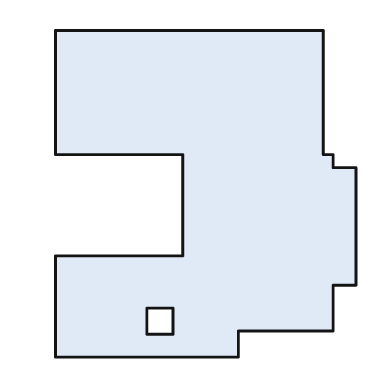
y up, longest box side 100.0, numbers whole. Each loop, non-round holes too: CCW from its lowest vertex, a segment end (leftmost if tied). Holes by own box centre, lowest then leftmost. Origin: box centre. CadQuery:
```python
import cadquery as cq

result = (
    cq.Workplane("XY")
    .moveTo(-46.0, -50.0)
    .lineTo(10.0, -50.0)
    .lineTo(10.0, -42.0)
    .lineTo(39.0, -42.0)
    .lineTo(39.0, -28.0)
    .lineTo(46.0, -28.0)
    .lineTo(46.0, 8.0)
    .lineTo(39.0, 8.0)
    .lineTo(39.0, 12.0)
    .lineTo(36.0, 12.0)
    .lineTo(36.0, 50.0)
    .lineTo(-46.0, 50.0)
    .lineTo(-46.0, 12.0)
    .lineTo(-7.0, 12.0)
    .lineTo(-7.0, -19.0)
    .lineTo(-46.0, -19.0)
    .close()
    .moveTo(-18.0, -43.0)
    .lineTo(-10.0, -43.0)
    .lineTo(-10.0, -35.0)
    .lineTo(-18.0, -35.0)
    .close()
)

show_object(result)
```